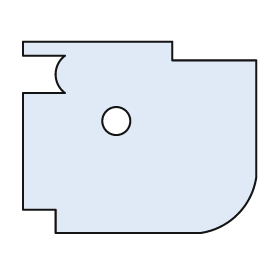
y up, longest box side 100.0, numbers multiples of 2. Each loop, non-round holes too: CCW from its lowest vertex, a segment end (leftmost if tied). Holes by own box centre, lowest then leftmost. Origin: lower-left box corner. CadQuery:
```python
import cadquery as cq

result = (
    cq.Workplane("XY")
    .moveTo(14.0, 0.0)
    .lineTo(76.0, 0.0)
    .threePointArc((92.0, 8.0), (100.0, 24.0))
    .lineTo(100.0, 74.0)
    .lineTo(64.0, 74.0)
    .lineTo(64.0, 82.0)
    .lineTo(0.0, 82.0)
    .lineTo(0.0, 76.0)
    .lineTo(18.0, 76.0)
    .threePointArc((14.0, 68.0), (18.0, 60.0))
    .lineTo(0.0, 60.0)
    .lineTo(0.0, 10.0)
    .lineTo(14.0, 10.0)
    .close()
    .moveTo(40.0, 48.0)
    .circle(6.0)
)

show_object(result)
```